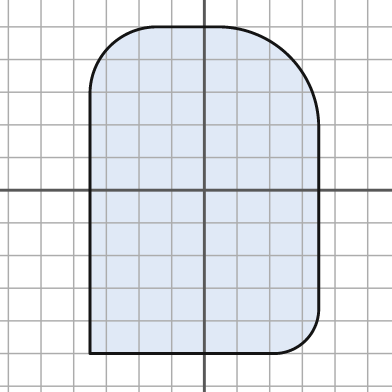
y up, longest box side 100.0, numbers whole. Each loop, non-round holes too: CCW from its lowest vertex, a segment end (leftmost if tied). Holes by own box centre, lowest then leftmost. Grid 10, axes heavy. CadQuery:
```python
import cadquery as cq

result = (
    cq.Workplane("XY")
    .moveTo(-35.0, -50.0)
    .lineTo(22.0, -50.0)
    .threePointArc((31.0, -46.0), (35.0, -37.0))
    .lineTo(35.0, 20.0)
    .threePointArc((26.0, 41.0), (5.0, 50.0))
    .lineTo(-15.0, 50.0)
    .threePointArc((-29.0, 44.0), (-35.0, 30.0))
    .close()
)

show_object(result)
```